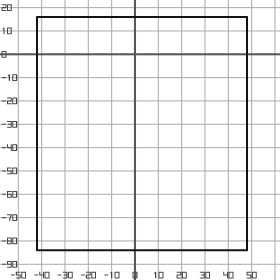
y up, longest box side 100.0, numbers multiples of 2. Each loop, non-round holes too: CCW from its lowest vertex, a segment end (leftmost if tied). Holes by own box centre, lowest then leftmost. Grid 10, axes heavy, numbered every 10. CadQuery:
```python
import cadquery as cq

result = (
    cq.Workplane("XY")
    .moveTo(-42.0, -84.0)
    .lineTo(48.0, -84.0)
    .lineTo(48.0, 16.0)
    .lineTo(-42.0, 16.0)
    .close()
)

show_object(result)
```